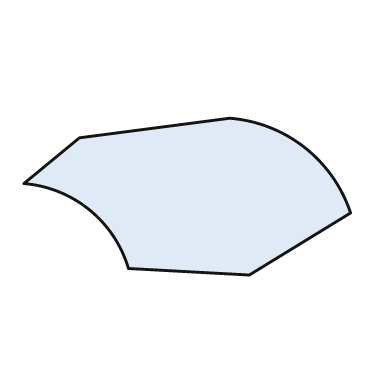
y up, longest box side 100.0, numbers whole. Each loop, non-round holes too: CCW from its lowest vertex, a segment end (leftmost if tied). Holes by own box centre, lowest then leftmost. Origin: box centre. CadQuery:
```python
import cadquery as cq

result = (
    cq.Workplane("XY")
    .moveTo(19.0, -24.0)
    .lineTo(50.0, -5.0)
    .threePointArc((36.0, 15.0), (13.0, 24.0))
    .lineTo(-33.0, 18.0)
    .lineTo(-50.0, 4.0)
    .threePointArc((-30.0, -4.0), (-18.0, -22.0))
    .close()
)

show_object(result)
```